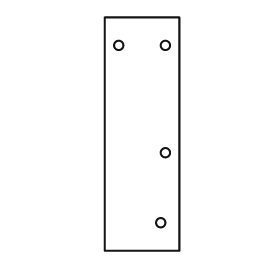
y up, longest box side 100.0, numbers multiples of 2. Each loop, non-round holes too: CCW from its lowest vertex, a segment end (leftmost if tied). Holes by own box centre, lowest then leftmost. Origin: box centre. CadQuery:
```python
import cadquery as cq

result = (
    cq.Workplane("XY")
    .moveTo(-16.0, -50.0)
    .lineTo(16.0, -50.0)
    .lineTo(16.0, 50.0)
    .lineTo(-16.0, 50.0)
    .close()
    .moveTo(8.0, -38.0)
    .circle(2.0)
    .moveTo(10.0, -8.0)
    .circle(2.0)
    .moveTo(-10.0, 38.0)
    .circle(2.0)
    .moveTo(10.0, 38.0)
    .circle(2.0)
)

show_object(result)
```